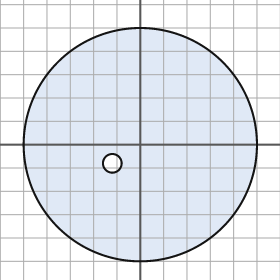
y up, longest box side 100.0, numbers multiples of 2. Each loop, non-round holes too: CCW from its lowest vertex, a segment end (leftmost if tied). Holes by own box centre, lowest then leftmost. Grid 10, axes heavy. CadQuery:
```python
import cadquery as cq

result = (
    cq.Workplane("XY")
    .moveTo(0.0, 0.0)
    .circle(50.0)
    .moveTo(-12.0, -8.0)
    .circle(4.0)
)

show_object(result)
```